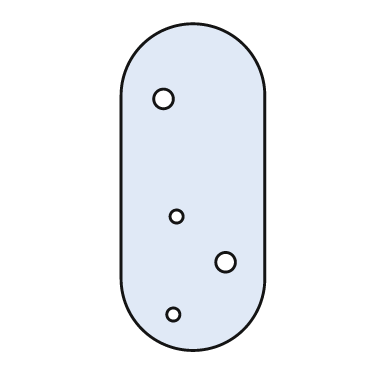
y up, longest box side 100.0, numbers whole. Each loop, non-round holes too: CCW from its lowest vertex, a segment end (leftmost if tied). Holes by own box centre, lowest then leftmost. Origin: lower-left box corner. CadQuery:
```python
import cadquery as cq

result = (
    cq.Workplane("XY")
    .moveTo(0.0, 22.0)
    .threePointArc((22.0, 0.0), (44.0, 22.0))
    .lineTo(44.0, 78.0)
    .threePointArc((22.0, 100.0), (0.0, 78.0))
    .close()
    .moveTo(16.0, 11.0)
    .circle(2.0)
    .moveTo(32.0, 27.0)
    .circle(3.0)
    .moveTo(17.0, 41.0)
    .circle(2.0)
    .moveTo(13.0, 77.0)
    .circle(3.0)
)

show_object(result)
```